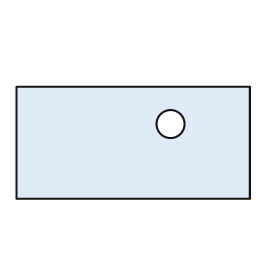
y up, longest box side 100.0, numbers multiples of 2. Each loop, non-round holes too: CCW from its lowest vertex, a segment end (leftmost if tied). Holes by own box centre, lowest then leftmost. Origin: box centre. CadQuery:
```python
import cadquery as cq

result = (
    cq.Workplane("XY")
    .moveTo(-50.0, -24.0)
    .lineTo(50.0, -24.0)
    .lineTo(50.0, 24.0)
    .lineTo(-50.0, 24.0)
    .close()
    .moveTo(16.0, 8.0)
    .circle(6.0)
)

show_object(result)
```